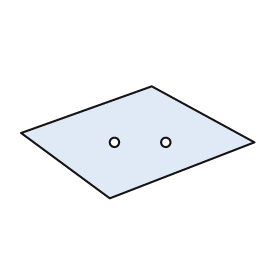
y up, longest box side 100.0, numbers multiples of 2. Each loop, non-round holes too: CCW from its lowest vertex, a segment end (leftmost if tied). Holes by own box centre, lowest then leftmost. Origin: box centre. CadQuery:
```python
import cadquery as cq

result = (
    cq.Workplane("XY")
    .moveTo(-12.0, -24.0)
    .lineTo(50.0, 0.0)
    .lineTo(6.0, 24.0)
    .lineTo(-50.0, 4.0)
    .close()
    .moveTo(-10.0, 0.0)
    .circle(2.0)
    .moveTo(12.0, 0.0)
    .circle(2.0)
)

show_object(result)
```